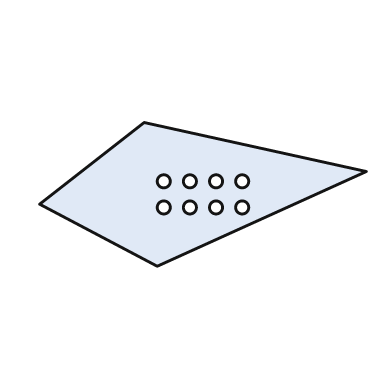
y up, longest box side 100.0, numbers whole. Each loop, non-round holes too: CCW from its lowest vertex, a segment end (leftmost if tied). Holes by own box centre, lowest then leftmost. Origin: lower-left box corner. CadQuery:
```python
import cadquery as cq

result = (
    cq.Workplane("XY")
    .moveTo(36.0, 0.0)
    .lineTo(100.0, 29.0)
    .lineTo(32.0, 44.0)
    .lineTo(0.0, 19.0)
    .close()
    .moveTo(38.0, 18.0)
    .circle(2.0)
    .moveTo(46.0, 18.0)
    .circle(2.0)
    .moveTo(54.0, 18.0)
    .circle(2.0)
    .moveTo(62.0, 18.0)
    .circle(2.0)
    .moveTo(38.0, 26.0)
    .circle(2.0)
    .moveTo(46.0, 26.0)
    .circle(2.0)
    .moveTo(54.0, 26.0)
    .circle(2.0)
    .moveTo(62.0, 26.0)
    .circle(2.0)
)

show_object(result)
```